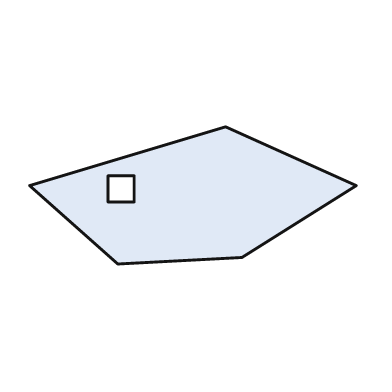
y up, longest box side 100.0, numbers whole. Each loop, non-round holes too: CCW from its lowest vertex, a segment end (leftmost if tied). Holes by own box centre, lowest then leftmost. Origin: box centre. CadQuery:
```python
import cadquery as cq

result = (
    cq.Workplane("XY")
    .moveTo(-23.0, -21.0)
    .lineTo(15.0, -19.0)
    .lineTo(50.0, 3.0)
    .lineTo(10.0, 21.0)
    .lineTo(-50.0, 3.0)
    .close()
    .moveTo(-26.0, -2.0)
    .lineTo(-18.0, -2.0)
    .lineTo(-18.0, 6.0)
    .lineTo(-26.0, 6.0)
    .close()
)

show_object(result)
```